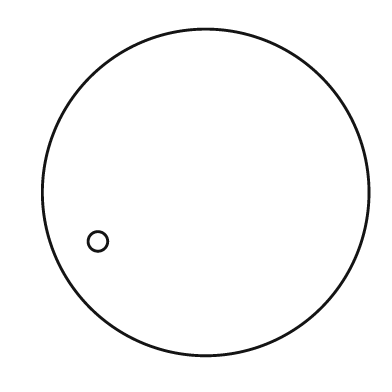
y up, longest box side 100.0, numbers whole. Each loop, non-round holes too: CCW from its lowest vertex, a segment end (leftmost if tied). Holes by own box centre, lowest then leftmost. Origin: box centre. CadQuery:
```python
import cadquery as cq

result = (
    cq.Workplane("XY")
    .moveTo(0.0, 0.0)
    .circle(50.0)
    .moveTo(-33.0, -15.0)
    .circle(3.0)
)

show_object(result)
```